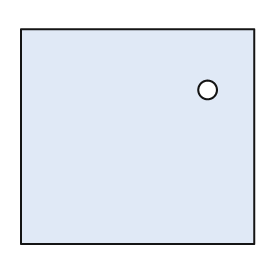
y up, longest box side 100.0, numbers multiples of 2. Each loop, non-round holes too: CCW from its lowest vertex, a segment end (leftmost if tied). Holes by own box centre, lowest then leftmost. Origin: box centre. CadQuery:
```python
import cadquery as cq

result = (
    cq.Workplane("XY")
    .moveTo(-50.0, -46.0)
    .lineTo(50.0, -46.0)
    .lineTo(50.0, 46.0)
    .lineTo(-50.0, 46.0)
    .close()
    .moveTo(30.0, 20.0)
    .circle(4.0)
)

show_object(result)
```